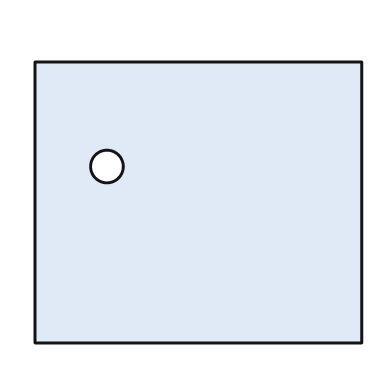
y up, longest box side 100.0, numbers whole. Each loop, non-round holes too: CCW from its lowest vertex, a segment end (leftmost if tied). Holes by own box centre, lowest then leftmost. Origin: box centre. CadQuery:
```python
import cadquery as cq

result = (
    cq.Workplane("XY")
    .moveTo(-50.0, -43.0)
    .lineTo(50.0, -43.0)
    .lineTo(50.0, 43.0)
    .lineTo(-50.0, 43.0)
    .close()
    .moveTo(-28.0, 11.0)
    .circle(5.0)
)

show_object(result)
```